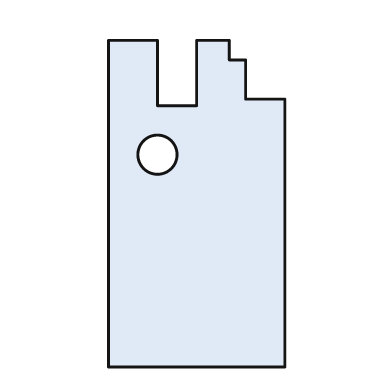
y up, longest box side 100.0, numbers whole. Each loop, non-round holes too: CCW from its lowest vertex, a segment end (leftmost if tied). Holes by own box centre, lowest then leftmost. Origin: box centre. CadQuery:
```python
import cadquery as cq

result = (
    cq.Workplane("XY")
    .moveTo(-27.0, -50.0)
    .lineTo(27.0, -50.0)
    .lineTo(27.0, 32.0)
    .lineTo(15.0, 32.0)
    .lineTo(15.0, 44.0)
    .lineTo(10.0, 44.0)
    .lineTo(10.0, 50.0)
    .lineTo(0.0, 50.0)
    .lineTo(0.0, 30.0)
    .lineTo(-12.0, 30.0)
    .lineTo(-12.0, 50.0)
    .lineTo(-27.0, 50.0)
    .close()
    .moveTo(-12.0, 15.0)
    .circle(6.0)
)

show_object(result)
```